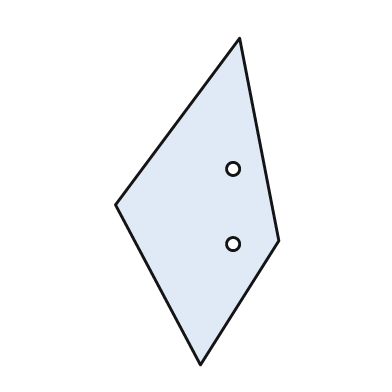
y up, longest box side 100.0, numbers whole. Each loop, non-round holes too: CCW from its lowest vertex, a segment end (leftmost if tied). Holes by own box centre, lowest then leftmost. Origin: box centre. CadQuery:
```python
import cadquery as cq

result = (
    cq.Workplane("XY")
    .moveTo(1.0, -50.0)
    .lineTo(25.0, -12.0)
    .lineTo(13.0, 50.0)
    .lineTo(-25.0, -1.0)
    .close()
    .moveTo(11.0, -13.0)
    .circle(2.0)
    .moveTo(11.0, 10.0)
    .circle(2.0)
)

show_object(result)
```